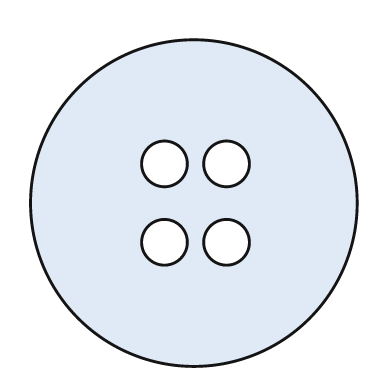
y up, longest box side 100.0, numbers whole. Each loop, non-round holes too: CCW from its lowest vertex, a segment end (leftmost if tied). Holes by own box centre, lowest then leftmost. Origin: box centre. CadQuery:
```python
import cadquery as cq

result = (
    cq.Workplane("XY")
    .moveTo(0.0, 0.0)
    .circle(50.0)
    .moveTo(-9.0, -12.0)
    .circle(7.0)
    .moveTo(10.0, -12.0)
    .circle(7.0)
    .moveTo(-9.0, 12.0)
    .circle(7.0)
    .moveTo(10.0, 12.0)
    .circle(7.0)
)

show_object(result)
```